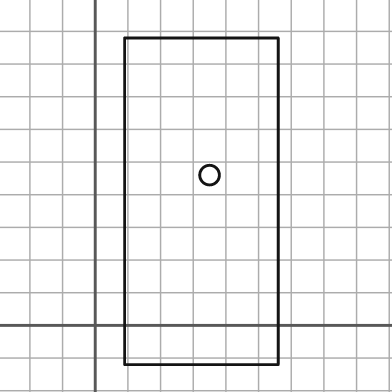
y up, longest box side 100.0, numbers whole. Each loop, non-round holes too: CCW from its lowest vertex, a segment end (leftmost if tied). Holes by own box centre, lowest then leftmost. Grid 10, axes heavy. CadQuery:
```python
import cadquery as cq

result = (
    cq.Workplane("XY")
    .moveTo(9.0, -12.0)
    .lineTo(56.0, -12.0)
    .lineTo(56.0, 88.0)
    .lineTo(9.0, 88.0)
    .close()
    .moveTo(35.0, 46.0)
    .circle(3.0)
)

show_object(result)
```